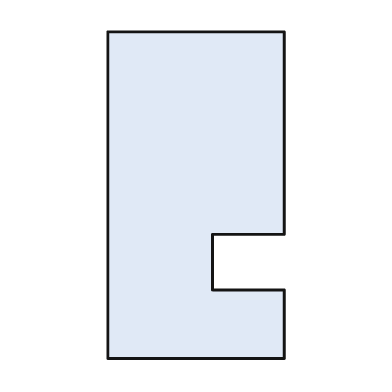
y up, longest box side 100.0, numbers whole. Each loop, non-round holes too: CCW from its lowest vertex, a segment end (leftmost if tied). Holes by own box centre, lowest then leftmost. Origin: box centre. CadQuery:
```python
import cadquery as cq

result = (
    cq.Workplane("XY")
    .moveTo(-27.0, -50.0)
    .lineTo(27.0, -50.0)
    .lineTo(27.0, -29.0)
    .lineTo(5.0, -29.0)
    .lineTo(5.0, -12.0)
    .lineTo(27.0, -12.0)
    .lineTo(27.0, 50.0)
    .lineTo(-27.0, 50.0)
    .close()
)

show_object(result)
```